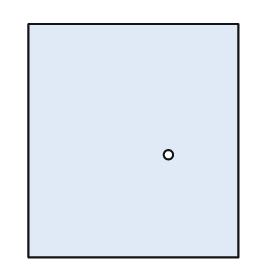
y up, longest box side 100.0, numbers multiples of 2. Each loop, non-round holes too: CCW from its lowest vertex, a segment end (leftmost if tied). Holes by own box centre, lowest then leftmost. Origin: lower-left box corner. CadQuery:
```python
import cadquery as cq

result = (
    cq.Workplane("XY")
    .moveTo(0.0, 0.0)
    .lineTo(90.0, 0.0)
    .lineTo(90.0, 100.0)
    .lineTo(0.0, 100.0)
    .close()
    .moveTo(60.0, 44.0)
    .circle(2.0)
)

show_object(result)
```